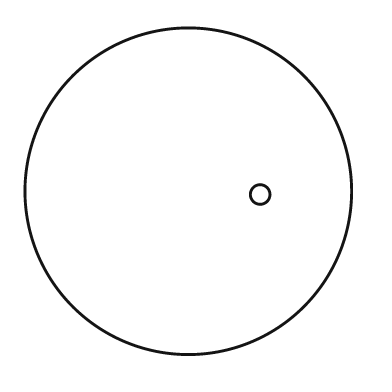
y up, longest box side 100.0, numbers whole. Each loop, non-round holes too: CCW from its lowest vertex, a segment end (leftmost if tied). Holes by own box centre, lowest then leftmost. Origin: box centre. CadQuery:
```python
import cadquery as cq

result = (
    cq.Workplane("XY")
    .moveTo(0.0, 0.0)
    .circle(50.0)
    .moveTo(22.0, -1.0)
    .circle(3.0)
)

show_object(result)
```